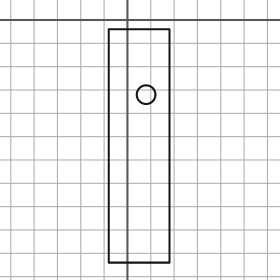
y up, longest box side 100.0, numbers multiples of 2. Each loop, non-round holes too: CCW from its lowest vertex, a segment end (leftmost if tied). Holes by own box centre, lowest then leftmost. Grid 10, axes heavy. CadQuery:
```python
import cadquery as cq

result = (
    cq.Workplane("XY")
    .moveTo(-8.0, -104.0)
    .lineTo(18.0, -104.0)
    .lineTo(18.0, -4.0)
    .lineTo(-8.0, -4.0)
    .close()
    .moveTo(8.0, -32.0)
    .circle(4.0)
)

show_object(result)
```